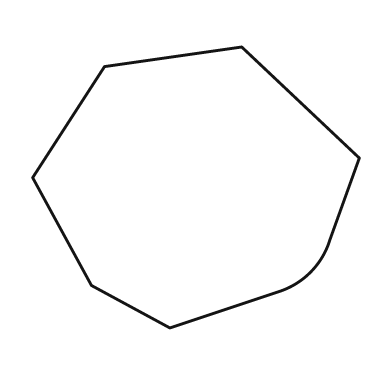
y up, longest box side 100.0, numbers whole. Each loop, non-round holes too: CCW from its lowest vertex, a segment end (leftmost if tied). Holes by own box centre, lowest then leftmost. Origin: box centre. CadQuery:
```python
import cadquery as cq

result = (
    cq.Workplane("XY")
    .moveTo(-8.0, -43.0)
    .lineTo(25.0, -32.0)
    .threePointArc((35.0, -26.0), (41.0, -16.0))
    .lineTo(50.0, 9.0)
    .lineTo(14.0, 43.0)
    .lineTo(-28.0, 37.0)
    .lineTo(-50.0, 3.0)
    .lineTo(-32.0, -30.0)
    .close()
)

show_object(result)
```